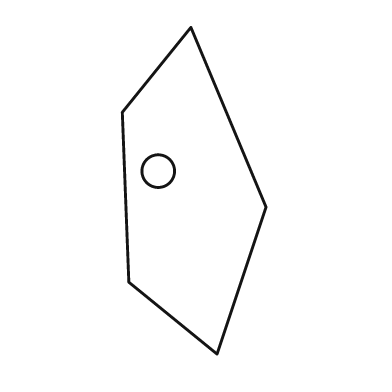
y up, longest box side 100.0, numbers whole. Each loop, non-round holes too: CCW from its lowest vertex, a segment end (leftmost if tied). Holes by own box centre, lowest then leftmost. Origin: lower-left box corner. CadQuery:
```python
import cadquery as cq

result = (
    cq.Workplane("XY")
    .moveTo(29.0, 0.0)
    .lineTo(44.0, 45.0)
    .lineTo(21.0, 100.0)
    .lineTo(0.0, 74.0)
    .lineTo(2.0, 22.0)
    .close()
    .moveTo(11.0, 56.0)
    .circle(5.0)
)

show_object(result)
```